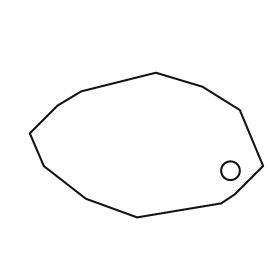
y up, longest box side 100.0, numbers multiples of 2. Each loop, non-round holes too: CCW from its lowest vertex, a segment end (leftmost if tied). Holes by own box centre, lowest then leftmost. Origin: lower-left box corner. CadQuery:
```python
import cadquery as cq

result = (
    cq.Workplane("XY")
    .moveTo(46.0, 0.0)
    .lineTo(82.0, 6.0)
    .lineTo(88.0, 10.0)
    .lineTo(100.0, 22.0)
    .lineTo(90.0, 46.0)
    .lineTo(74.0, 56.0)
    .lineTo(54.0, 62.0)
    .lineTo(22.0, 54.0)
    .lineTo(12.0, 48.0)
    .lineTo(0.0, 36.0)
    .lineTo(6.0, 22.0)
    .lineTo(24.0, 8.0)
    .close()
    .moveTo(86.0, 20.0)
    .circle(4.0)
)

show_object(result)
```